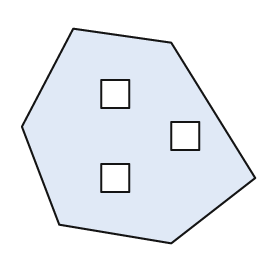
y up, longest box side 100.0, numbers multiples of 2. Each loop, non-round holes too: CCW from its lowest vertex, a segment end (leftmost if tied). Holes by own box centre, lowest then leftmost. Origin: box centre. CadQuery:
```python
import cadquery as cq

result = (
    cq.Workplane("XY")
    .moveTo(14.0, -46.0)
    .lineTo(50.0, -18.0)
    .lineTo(14.0, 40.0)
    .lineTo(-28.0, 46.0)
    .lineTo(-50.0, 4.0)
    .lineTo(-34.0, -38.0)
    .close()
    .moveTo(-16.0, -24.0)
    .lineTo(-4.0, -24.0)
    .lineTo(-4.0, -12.0)
    .lineTo(-16.0, -12.0)
    .close()
    .moveTo(14.0, -6.0)
    .lineTo(26.0, -6.0)
    .lineTo(26.0, 6.0)
    .lineTo(14.0, 6.0)
    .close()
    .moveTo(-16.0, 12.0)
    .lineTo(-4.0, 12.0)
    .lineTo(-4.0, 24.0)
    .lineTo(-16.0, 24.0)
    .close()
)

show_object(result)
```